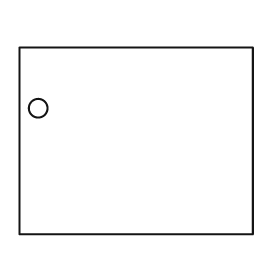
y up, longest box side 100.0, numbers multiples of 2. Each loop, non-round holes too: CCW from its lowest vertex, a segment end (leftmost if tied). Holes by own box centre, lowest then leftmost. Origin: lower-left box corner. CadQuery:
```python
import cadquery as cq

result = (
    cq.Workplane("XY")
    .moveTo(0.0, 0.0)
    .lineTo(100.0, 0.0)
    .lineTo(100.0, 80.0)
    .lineTo(0.0, 80.0)
    .close()
    .moveTo(8.0, 54.0)
    .circle(4.0)
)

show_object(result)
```